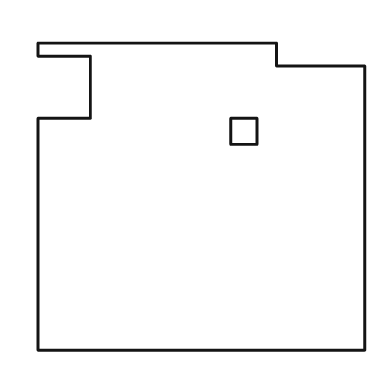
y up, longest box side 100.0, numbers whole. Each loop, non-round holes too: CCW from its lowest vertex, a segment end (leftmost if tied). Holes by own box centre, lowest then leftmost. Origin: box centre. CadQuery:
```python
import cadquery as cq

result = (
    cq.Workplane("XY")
    .moveTo(-50.0, -47.0)
    .lineTo(50.0, -47.0)
    .lineTo(50.0, 40.0)
    .lineTo(23.0, 40.0)
    .lineTo(23.0, 47.0)
    .lineTo(-50.0, 47.0)
    .lineTo(-50.0, 43.0)
    .lineTo(-34.0, 43.0)
    .lineTo(-34.0, 24.0)
    .lineTo(-50.0, 24.0)
    .close()
    .moveTo(9.0, 16.0)
    .lineTo(17.0, 16.0)
    .lineTo(17.0, 24.0)
    .lineTo(9.0, 24.0)
    .close()
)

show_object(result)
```